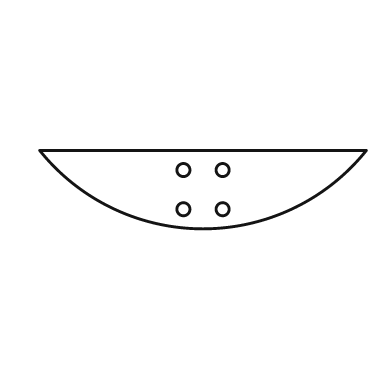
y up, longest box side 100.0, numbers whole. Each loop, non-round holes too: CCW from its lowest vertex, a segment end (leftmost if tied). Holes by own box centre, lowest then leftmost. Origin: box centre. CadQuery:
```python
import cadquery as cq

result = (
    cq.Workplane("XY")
    .moveTo(-50.0, 12.0)
    .threePointArc((0.0, -12.0), (50.0, 12.0))
    .close()
    .moveTo(-6.0, -6.0)
    .circle(2.0)
    .moveTo(6.0, -6.0)
    .circle(2.0)
    .moveTo(-6.0, 6.0)
    .circle(2.0)
    .moveTo(6.0, 6.0)
    .circle(2.0)
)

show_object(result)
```